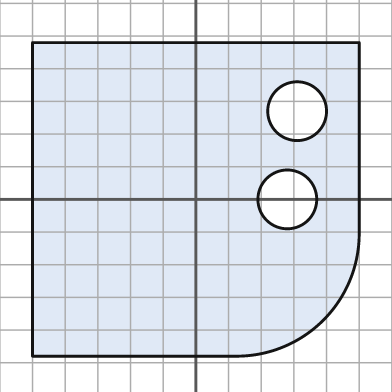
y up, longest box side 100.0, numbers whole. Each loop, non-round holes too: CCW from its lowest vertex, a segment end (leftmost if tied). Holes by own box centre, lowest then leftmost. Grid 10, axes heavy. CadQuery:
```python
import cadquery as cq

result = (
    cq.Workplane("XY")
    .moveTo(-50.0, -48.0)
    .lineTo(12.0, -48.0)
    .threePointArc((39.0, -37.0), (50.0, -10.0))
    .lineTo(50.0, 48.0)
    .lineTo(-50.0, 48.0)
    .close()
    .moveTo(28.0, 0.0)
    .circle(9.0)
    .moveTo(31.0, 27.0)
    .circle(9.0)
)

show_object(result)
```